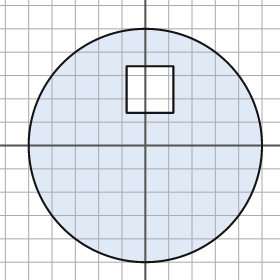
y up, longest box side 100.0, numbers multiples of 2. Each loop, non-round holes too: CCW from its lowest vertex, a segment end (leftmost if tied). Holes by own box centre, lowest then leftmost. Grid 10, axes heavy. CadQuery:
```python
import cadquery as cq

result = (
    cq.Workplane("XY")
    .moveTo(0.0, 0.0)
    .circle(50.0)
    .moveTo(-8.0, 14.0)
    .lineTo(12.0, 14.0)
    .lineTo(12.0, 34.0)
    .lineTo(-8.0, 34.0)
    .close()
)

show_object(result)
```